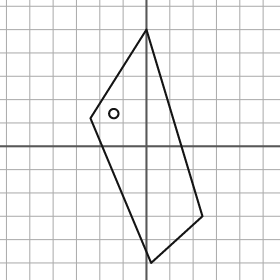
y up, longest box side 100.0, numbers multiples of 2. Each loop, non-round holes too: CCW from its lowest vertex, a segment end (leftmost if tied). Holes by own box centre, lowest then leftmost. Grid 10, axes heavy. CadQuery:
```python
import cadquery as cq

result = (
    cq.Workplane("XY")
    .moveTo(2.0, -50.0)
    .lineTo(24.0, -30.0)
    .lineTo(0.0, 50.0)
    .lineTo(-24.0, 12.0)
    .close()
    .moveTo(-14.0, 14.0)
    .circle(2.0)
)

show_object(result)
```